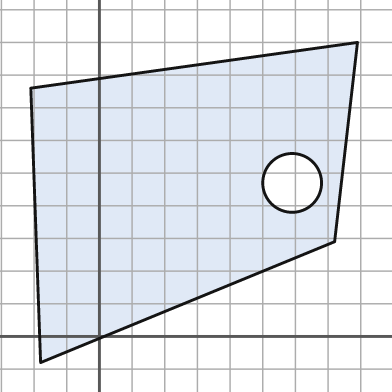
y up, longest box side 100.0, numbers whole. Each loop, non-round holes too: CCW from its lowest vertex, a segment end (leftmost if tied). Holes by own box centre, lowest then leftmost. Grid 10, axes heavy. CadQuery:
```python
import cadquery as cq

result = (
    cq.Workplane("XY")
    .moveTo(-18.0, -8.0)
    .lineTo(72.0, 29.0)
    .lineTo(79.0, 90.0)
    .lineTo(-21.0, 76.0)
    .close()
    .moveTo(59.0, 47.0)
    .circle(9.0)
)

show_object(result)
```